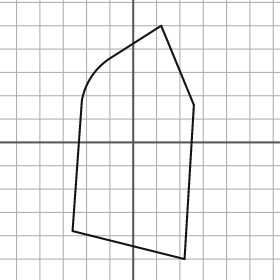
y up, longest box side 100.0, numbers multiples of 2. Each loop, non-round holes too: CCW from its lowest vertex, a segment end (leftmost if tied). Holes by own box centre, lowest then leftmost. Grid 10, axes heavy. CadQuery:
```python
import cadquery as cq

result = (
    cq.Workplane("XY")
    .moveTo(22.0, -50.0)
    .lineTo(26.0, 16.0)
    .lineTo(12.0, 50.0)
    .lineTo(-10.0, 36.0)
    .threePointArc((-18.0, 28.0), (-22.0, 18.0))
    .lineTo(-26.0, -38.0)
    .close()
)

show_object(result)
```